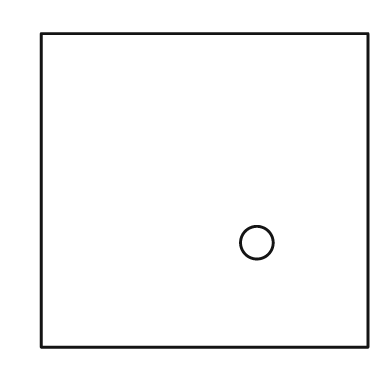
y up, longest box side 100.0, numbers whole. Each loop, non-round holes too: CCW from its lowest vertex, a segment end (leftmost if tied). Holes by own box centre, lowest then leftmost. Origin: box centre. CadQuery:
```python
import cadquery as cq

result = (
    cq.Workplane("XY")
    .moveTo(-50.0, -48.0)
    .lineTo(50.0, -48.0)
    .lineTo(50.0, 48.0)
    .lineTo(-50.0, 48.0)
    .close()
    .moveTo(16.0, -16.0)
    .circle(5.0)
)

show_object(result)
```